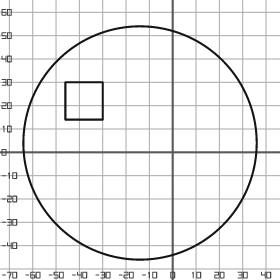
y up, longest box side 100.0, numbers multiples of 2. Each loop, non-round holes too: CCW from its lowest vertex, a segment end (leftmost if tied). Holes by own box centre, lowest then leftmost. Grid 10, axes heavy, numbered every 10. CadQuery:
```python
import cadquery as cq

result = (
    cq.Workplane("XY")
    .moveTo(-14.0, 4.0)
    .circle(50.0)
    .moveTo(-46.0, 14.0)
    .lineTo(-30.0, 14.0)
    .lineTo(-30.0, 30.0)
    .lineTo(-46.0, 30.0)
    .close()
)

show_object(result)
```